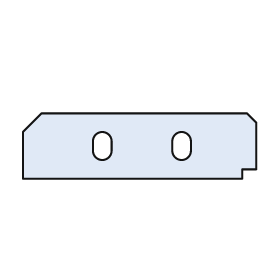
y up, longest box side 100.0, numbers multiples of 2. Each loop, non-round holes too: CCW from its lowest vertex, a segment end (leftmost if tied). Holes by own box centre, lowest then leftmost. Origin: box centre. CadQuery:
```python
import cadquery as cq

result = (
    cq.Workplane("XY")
    .moveTo(-50.0, -14.0)
    .lineTo(44.0, -14.0)
    .lineTo(44.0, -10.0)
    .lineTo(50.0, -10.0)
    .lineTo(50.0, 10.0)
    .lineTo(46.0, 14.0)
    .lineTo(-42.0, 14.0)
    .lineTo(-50.0, 6.0)
    .close()
    .moveTo(-20.0, -2.0)
    .threePointArc((-16.0, -6.0), (-12.0, -2.0))
    .lineTo(-12.0, 2.0)
    .threePointArc((-16.0, 6.0), (-20.0, 2.0))
    .close()
    .moveTo(14.0, -2.0)
    .threePointArc((18.0, -6.0), (22.0, -2.0))
    .lineTo(22.0, 2.0)
    .threePointArc((18.0, 6.0), (14.0, 2.0))
    .close()
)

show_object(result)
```